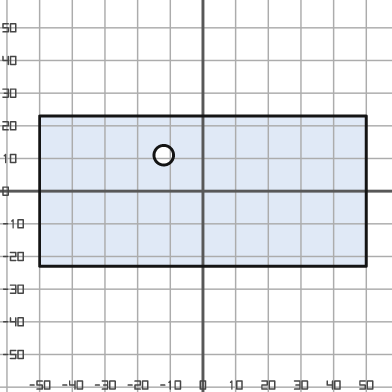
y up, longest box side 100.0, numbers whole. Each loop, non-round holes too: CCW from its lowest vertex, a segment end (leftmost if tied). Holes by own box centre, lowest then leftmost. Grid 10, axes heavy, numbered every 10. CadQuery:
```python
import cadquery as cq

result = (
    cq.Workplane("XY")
    .moveTo(-50.0, -23.0)
    .lineTo(50.0, -23.0)
    .lineTo(50.0, 23.0)
    .lineTo(-50.0, 23.0)
    .close()
    .moveTo(-12.0, 11.0)
    .circle(3.0)
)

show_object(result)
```